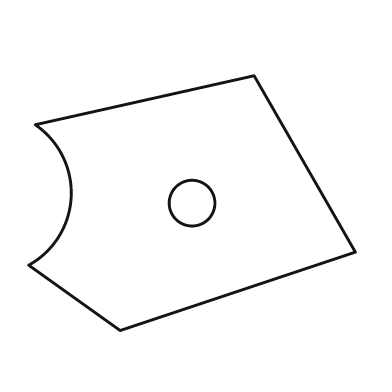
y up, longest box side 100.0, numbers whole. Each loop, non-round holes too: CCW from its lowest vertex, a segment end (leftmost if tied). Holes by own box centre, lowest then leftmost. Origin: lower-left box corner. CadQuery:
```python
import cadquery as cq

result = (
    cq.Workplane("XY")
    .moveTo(28.0, 0.0)
    .lineTo(100.0, 24.0)
    .lineTo(69.0, 78.0)
    .lineTo(2.0, 63.0)
    .threePointArc((13.0, 41.0), (0.0, 20.0))
    .close()
    .moveTo(50.0, 39.0)
    .circle(7.0)
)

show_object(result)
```